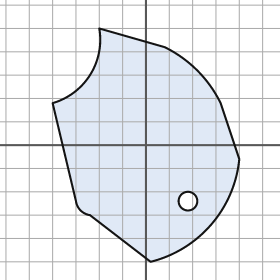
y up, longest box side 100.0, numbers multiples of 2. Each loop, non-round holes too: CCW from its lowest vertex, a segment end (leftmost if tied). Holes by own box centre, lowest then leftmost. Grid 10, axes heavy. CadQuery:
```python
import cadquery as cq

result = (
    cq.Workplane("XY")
    .moveTo(2.0, -50.0)
    .threePointArc((28.0, -34.0), (40.0, -6.0))
    .lineTo(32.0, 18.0)
    .threePointArc((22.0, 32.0), (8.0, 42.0))
    .lineTo(-20.0, 50.0)
    .threePointArc((-24.0, 30.0), (-40.0, 18.0))
    .lineTo(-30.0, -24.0)
    .threePointArc((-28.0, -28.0), (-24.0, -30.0))
    .close()
    .moveTo(18.0, -24.0)
    .circle(4.0)
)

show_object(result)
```